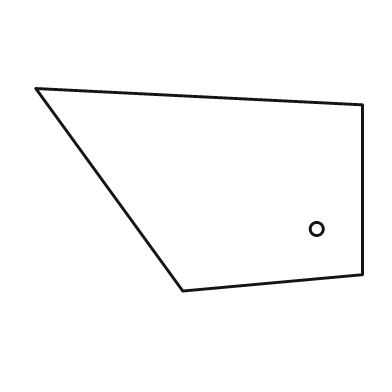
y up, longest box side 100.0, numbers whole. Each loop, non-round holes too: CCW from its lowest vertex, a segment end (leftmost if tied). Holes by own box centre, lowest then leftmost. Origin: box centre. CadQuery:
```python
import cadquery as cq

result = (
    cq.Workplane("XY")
    .moveTo(-5.0, -31.0)
    .lineTo(50.0, -26.0)
    .lineTo(50.0, 26.0)
    .lineTo(-50.0, 31.0)
    .close()
    .moveTo(36.0, -12.0)
    .circle(2.0)
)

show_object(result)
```